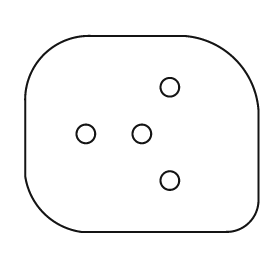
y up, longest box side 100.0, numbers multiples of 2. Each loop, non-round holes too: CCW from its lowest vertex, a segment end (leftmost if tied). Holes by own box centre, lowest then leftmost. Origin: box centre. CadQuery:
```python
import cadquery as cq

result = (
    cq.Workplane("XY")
    .moveTo(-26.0, -42.0)
    .lineTo(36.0, -42.0)
    .threePointArc((46.0, -38.0), (50.0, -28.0))
    .lineTo(50.0, 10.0)
    .threePointArc((40.0, 32.0), (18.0, 42.0))
    .lineTo(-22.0, 42.0)
    .threePointArc((-42.0, 34.0), (-50.0, 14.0))
    .lineTo(-50.0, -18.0)
    .threePointArc((-42.0, -34.0), (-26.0, -42.0))
    .close()
    .moveTo(12.0, -20.0)
    .circle(4.0)
    .moveTo(-24.0, 0.0)
    .circle(4.0)
    .moveTo(0.0, 0.0)
    .circle(4.0)
    .moveTo(12.0, 20.0)
    .circle(4.0)
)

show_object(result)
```